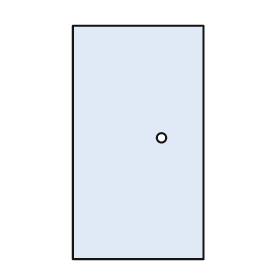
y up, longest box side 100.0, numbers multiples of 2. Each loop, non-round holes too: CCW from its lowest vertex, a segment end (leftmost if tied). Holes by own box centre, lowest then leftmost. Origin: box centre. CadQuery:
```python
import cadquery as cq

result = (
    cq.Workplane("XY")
    .moveTo(-28.0, -50.0)
    .lineTo(28.0, -50.0)
    .lineTo(28.0, 50.0)
    .lineTo(-28.0, 50.0)
    .close()
    .moveTo(10.0, 2.0)
    .circle(2.0)
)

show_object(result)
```